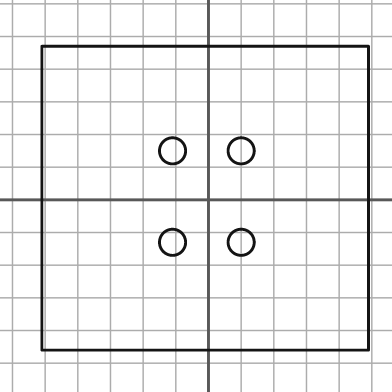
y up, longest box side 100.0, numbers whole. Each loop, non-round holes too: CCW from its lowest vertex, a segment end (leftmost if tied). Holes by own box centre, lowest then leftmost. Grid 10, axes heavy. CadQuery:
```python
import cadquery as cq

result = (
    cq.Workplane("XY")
    .moveTo(-51.0, -46.0)
    .lineTo(49.0, -46.0)
    .lineTo(49.0, 47.0)
    .lineTo(-51.0, 47.0)
    .close()
    .moveTo(-11.0, -13.0)
    .circle(4.0)
    .moveTo(10.0, -13.0)
    .circle(4.0)
    .moveTo(-11.0, 15.0)
    .circle(4.0)
    .moveTo(10.0, 15.0)
    .circle(4.0)
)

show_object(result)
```